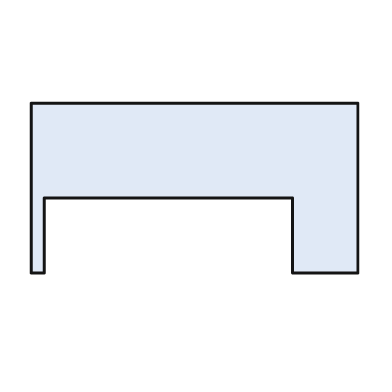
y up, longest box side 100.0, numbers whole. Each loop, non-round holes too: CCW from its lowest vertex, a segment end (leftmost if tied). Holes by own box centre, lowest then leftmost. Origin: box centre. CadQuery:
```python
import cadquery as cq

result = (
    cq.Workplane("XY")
    .moveTo(-50.0, -26.0)
    .lineTo(-46.0, -26.0)
    .lineTo(-46.0, -3.0)
    .lineTo(30.0, -3.0)
    .lineTo(30.0, -26.0)
    .lineTo(50.0, -26.0)
    .lineTo(50.0, 26.0)
    .lineTo(-50.0, 26.0)
    .close()
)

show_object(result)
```